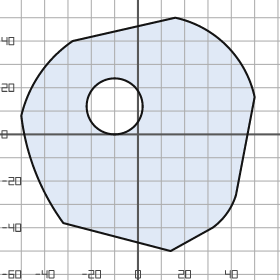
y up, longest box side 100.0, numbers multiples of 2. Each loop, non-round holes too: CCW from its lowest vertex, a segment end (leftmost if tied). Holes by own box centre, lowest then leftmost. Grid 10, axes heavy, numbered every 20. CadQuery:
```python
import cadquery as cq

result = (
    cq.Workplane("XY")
    .moveTo(14.0, -50.0)
    .lineTo(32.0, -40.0)
    .threePointArc((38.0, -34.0), (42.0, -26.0))
    .lineTo(50.0, 16.0)
    .threePointArc((38.0, 38.0), (16.0, 50.0))
    .lineTo(-28.0, 40.0)
    .threePointArc((-42.0, 26.0), (-50.0, 8.0))
    .threePointArc((-44.0, -16.0), (-32.0, -38.0))
    .close()
    .moveTo(-10.0, 12.0)
    .circle(12.0)
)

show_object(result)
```